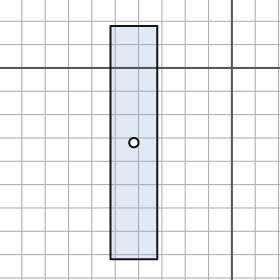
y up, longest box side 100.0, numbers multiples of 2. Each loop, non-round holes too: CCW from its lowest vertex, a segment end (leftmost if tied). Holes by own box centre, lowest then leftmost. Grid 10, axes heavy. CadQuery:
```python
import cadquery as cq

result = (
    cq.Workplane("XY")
    .moveTo(-52.0, -82.0)
    .lineTo(-32.0, -82.0)
    .lineTo(-32.0, 18.0)
    .lineTo(-52.0, 18.0)
    .close()
    .moveTo(-42.0, -32.0)
    .circle(2.0)
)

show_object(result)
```